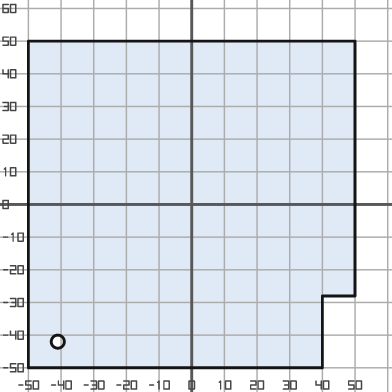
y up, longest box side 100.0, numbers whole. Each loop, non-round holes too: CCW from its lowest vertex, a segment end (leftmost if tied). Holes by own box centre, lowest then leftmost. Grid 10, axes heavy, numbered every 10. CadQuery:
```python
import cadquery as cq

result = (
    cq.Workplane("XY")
    .moveTo(-50.0, -50.0)
    .lineTo(40.0, -50.0)
    .lineTo(40.0, -28.0)
    .lineTo(50.0, -28.0)
    .lineTo(50.0, 50.0)
    .lineTo(-50.0, 50.0)
    .close()
    .moveTo(-41.0, -42.0)
    .circle(2.0)
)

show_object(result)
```